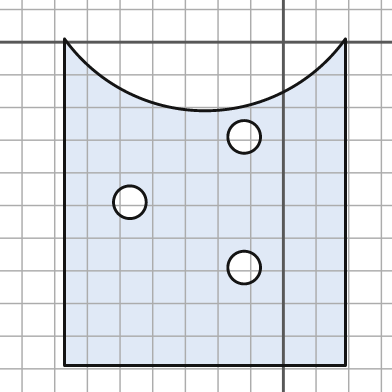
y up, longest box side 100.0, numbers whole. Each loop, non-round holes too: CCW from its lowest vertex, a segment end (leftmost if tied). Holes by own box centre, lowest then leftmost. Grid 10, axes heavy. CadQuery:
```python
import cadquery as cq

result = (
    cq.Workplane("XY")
    .moveTo(-67.0, -99.0)
    .lineTo(19.0, -99.0)
    .lineTo(19.0, 1.0)
    .threePointArc((-24.0, -21.0), (-67.0, 1.0))
    .close()
    .moveTo(-12.0, -69.0)
    .circle(5.0)
    .moveTo(-47.0, -49.0)
    .circle(5.0)
    .moveTo(-12.0, -29.0)
    .circle(5.0)
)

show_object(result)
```